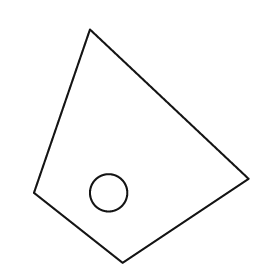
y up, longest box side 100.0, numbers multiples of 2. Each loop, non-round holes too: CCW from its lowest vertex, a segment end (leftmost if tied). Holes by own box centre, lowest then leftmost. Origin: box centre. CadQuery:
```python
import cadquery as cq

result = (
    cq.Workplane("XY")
    .moveTo(-8.0, -50.0)
    .lineTo(46.0, -14.0)
    .lineTo(-22.0, 50.0)
    .lineTo(-46.0, -20.0)
    .close()
    .moveTo(-14.0, -20.0)
    .circle(8.0)
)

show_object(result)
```